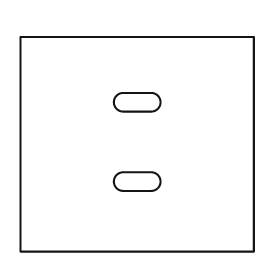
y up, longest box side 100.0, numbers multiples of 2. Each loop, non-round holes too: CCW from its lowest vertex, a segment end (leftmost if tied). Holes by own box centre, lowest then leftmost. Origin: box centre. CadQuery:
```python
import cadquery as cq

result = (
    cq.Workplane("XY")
    .moveTo(-50.0, -46.0)
    .lineTo(50.0, -46.0)
    .lineTo(50.0, 46.0)
    .lineTo(-50.0, 46.0)
    .close()
    .moveTo(-6.0, -20.0)
    .lineTo(6.0, -20.0)
    .threePointArc((10.0, -16.0), (6.0, -12.0))
    .lineTo(-6.0, -12.0)
    .threePointArc((-10.0, -16.0), (-6.0, -20.0))
    .close()
    .moveTo(-6.0, 14.0)
    .lineTo(6.0, 14.0)
    .threePointArc((10.0, 18.0), (6.0, 22.0))
    .lineTo(-6.0, 22.0)
    .threePointArc((-10.0, 18.0), (-6.0, 14.0))
    .close()
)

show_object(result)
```